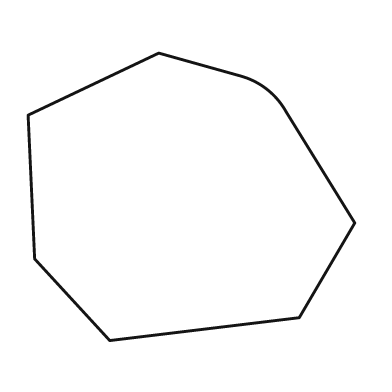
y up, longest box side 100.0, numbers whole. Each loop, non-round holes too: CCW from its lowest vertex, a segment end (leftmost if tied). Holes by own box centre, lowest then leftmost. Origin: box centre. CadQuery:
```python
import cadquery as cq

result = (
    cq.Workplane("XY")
    .moveTo(-25.0, -44.0)
    .lineTo(33.0, -37.0)
    .lineTo(50.0, -8.0)
    .lineTo(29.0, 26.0)
    .threePointArc((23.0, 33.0), (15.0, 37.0))
    .lineTo(-10.0, 44.0)
    .lineTo(-50.0, 25.0)
    .lineTo(-48.0, -19.0)
    .close()
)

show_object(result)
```